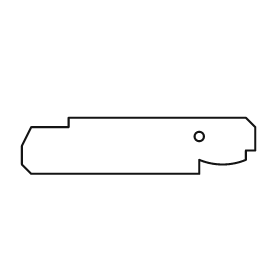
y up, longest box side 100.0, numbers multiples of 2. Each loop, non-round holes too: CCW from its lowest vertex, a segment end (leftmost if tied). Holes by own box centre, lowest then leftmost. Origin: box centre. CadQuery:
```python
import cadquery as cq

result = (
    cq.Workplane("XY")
    .moveTo(-46.0, -12.0)
    .lineTo(26.0, -12.0)
    .lineTo(26.0, -6.0)
    .threePointArc((36.0, -8.0), (46.0, -6.0))
    .lineTo(46.0, -2.0)
    .lineTo(50.0, -2.0)
    .lineTo(50.0, 8.0)
    .lineTo(46.0, 12.0)
    .lineTo(-30.0, 12.0)
    .lineTo(-30.0, 8.0)
    .lineTo(-46.0, 8.0)
    .lineTo(-50.0, 0.0)
    .lineTo(-50.0, -8.0)
    .close()
    .moveTo(26.0, 4.0)
    .circle(2.0)
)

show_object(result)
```